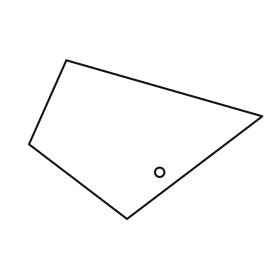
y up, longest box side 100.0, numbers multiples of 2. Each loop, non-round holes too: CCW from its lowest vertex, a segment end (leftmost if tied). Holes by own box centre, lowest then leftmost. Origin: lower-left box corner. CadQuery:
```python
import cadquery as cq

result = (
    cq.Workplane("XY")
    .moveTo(42.0, 0.0)
    .lineTo(100.0, 44.0)
    .lineTo(16.0, 68.0)
    .lineTo(0.0, 32.0)
    .close()
    .moveTo(56.0, 20.0)
    .circle(2.0)
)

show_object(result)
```